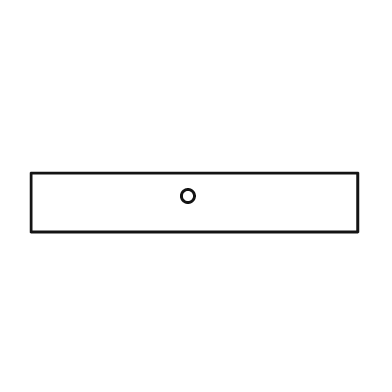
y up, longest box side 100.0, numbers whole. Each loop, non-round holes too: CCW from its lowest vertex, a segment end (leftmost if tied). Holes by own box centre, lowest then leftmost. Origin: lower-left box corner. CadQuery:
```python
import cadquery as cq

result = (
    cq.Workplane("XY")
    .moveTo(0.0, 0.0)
    .lineTo(100.0, 0.0)
    .lineTo(100.0, 18.0)
    .lineTo(0.0, 18.0)
    .close()
    .moveTo(48.0, 11.0)
    .circle(2.0)
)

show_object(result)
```